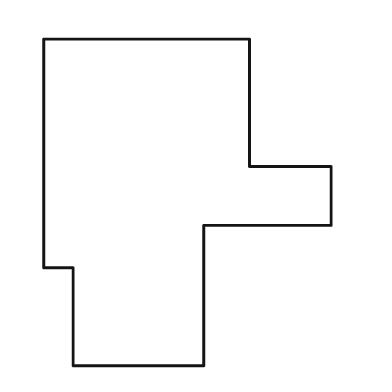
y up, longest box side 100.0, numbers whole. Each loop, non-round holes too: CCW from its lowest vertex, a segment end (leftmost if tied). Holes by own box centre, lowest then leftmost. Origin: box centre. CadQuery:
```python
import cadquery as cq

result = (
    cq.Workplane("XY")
    .moveTo(-35.0, -50.0)
    .lineTo(5.0, -50.0)
    .lineTo(5.0, -7.0)
    .lineTo(44.0, -7.0)
    .lineTo(44.0, 11.0)
    .lineTo(19.0, 11.0)
    .lineTo(19.0, 50.0)
    .lineTo(-44.0, 50.0)
    .lineTo(-44.0, -20.0)
    .lineTo(-35.0, -20.0)
    .close()
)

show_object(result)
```